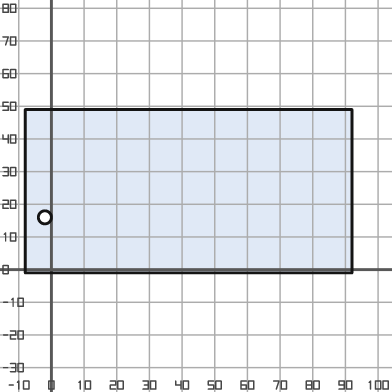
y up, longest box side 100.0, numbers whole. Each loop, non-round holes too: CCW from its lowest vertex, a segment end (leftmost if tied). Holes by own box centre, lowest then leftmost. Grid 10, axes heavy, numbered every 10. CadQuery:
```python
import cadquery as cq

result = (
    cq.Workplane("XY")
    .moveTo(-8.0, -1.0)
    .lineTo(92.0, -1.0)
    .lineTo(92.0, 49.0)
    .lineTo(-8.0, 49.0)
    .close()
    .moveTo(-2.0, 16.0)
    .circle(2.0)
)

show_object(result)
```